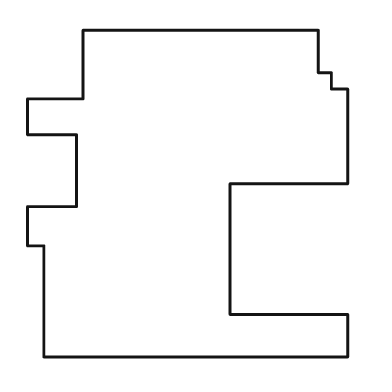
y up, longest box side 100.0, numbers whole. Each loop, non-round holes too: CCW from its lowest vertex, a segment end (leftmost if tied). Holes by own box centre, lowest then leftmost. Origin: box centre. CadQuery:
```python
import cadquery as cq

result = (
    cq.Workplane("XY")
    .moveTo(-44.0, -50.0)
    .lineTo(49.0, -50.0)
    .lineTo(49.0, -37.0)
    .lineTo(13.0, -37.0)
    .lineTo(13.0, 3.0)
    .lineTo(49.0, 3.0)
    .lineTo(49.0, 32.0)
    .lineTo(44.0, 32.0)
    .lineTo(44.0, 37.0)
    .lineTo(40.0, 37.0)
    .lineTo(40.0, 50.0)
    .lineTo(-32.0, 50.0)
    .lineTo(-32.0, 29.0)
    .lineTo(-49.0, 29.0)
    .lineTo(-49.0, 18.0)
    .lineTo(-34.0, 18.0)
    .lineTo(-34.0, -4.0)
    .lineTo(-49.0, -4.0)
    .lineTo(-49.0, -16.0)
    .lineTo(-44.0, -16.0)
    .close()
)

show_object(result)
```